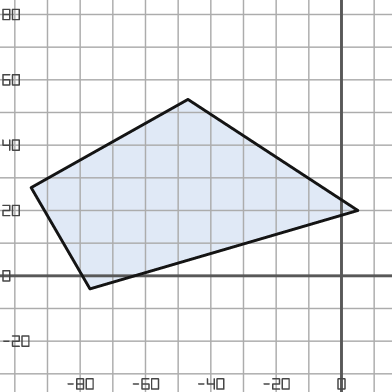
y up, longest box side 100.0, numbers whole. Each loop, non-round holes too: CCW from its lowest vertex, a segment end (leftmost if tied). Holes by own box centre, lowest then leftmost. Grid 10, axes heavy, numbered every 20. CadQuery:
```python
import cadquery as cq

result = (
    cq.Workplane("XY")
    .moveTo(-77.0, -4.0)
    .lineTo(5.0, 20.0)
    .lineTo(-47.0, 54.0)
    .lineTo(-95.0, 27.0)
    .close()
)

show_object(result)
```